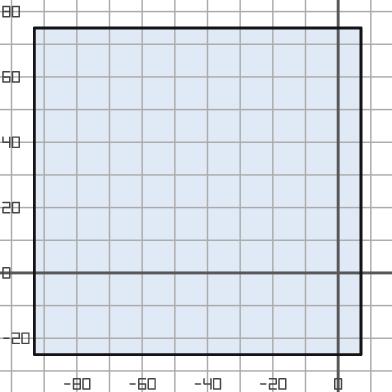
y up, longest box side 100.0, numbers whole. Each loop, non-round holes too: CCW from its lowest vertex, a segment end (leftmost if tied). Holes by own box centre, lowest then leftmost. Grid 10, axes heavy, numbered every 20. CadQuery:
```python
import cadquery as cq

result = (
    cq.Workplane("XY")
    .moveTo(-93.0, -25.0)
    .lineTo(7.0, -25.0)
    .lineTo(7.0, 75.0)
    .lineTo(-93.0, 75.0)
    .close()
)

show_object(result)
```